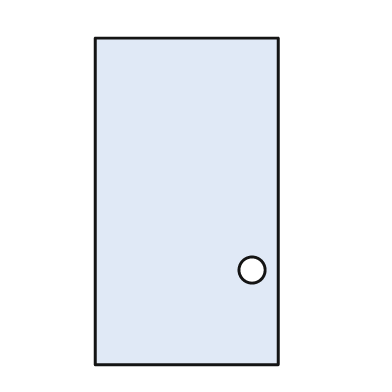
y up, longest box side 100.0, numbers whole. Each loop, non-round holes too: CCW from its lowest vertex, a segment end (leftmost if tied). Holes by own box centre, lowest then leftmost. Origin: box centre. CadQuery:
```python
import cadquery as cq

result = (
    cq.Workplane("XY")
    .moveTo(-28.0, -50.0)
    .lineTo(28.0, -50.0)
    .lineTo(28.0, 50.0)
    .lineTo(-28.0, 50.0)
    .close()
    .moveTo(20.0, -21.0)
    .circle(4.0)
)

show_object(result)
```